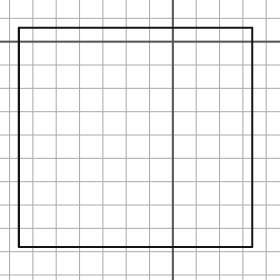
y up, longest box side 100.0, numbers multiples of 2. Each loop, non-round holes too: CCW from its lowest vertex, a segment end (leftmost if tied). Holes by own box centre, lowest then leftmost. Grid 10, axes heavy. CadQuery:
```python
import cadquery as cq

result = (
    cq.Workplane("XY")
    .moveTo(-66.0, -88.0)
    .lineTo(34.0, -88.0)
    .lineTo(34.0, 6.0)
    .lineTo(-66.0, 6.0)
    .close()
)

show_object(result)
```